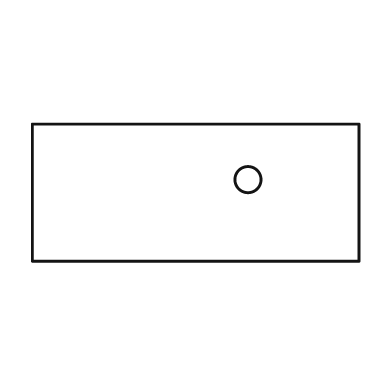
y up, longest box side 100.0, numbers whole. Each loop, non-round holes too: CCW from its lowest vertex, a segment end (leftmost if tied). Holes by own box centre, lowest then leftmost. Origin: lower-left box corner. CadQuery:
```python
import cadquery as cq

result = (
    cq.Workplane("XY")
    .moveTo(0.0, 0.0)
    .lineTo(100.0, 0.0)
    .lineTo(100.0, 42.0)
    .lineTo(0.0, 42.0)
    .close()
    .moveTo(66.0, 25.0)
    .circle(4.0)
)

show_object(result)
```